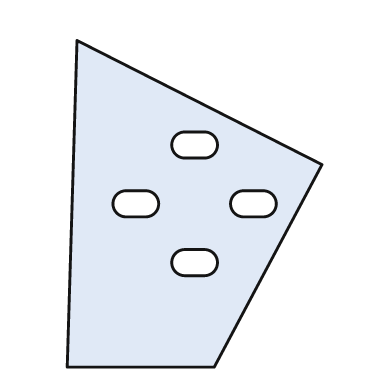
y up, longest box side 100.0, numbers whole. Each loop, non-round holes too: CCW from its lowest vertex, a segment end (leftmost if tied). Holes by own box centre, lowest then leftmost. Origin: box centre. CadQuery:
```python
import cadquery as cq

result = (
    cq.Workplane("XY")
    .moveTo(-39.0, -50.0)
    .lineTo(6.0, -50.0)
    .lineTo(39.0, 12.0)
    .lineTo(-36.0, 50.0)
    .close()
    .moveTo(-3.0, -22.0)
    .lineTo(3.0, -22.0)
    .threePointArc((7.0, -18.0), (3.0, -14.0))
    .lineTo(-3.0, -14.0)
    .threePointArc((-7.0, -18.0), (-3.0, -22.0))
    .close()
    .moveTo(-21.0, -4.0)
    .lineTo(-15.0, -4.0)
    .threePointArc((-11.0, 0.0), (-15.0, 4.0))
    .lineTo(-21.0, 4.0)
    .threePointArc((-25.0, 0.0), (-21.0, -4.0))
    .close()
    .moveTo(15.0, -4.0)
    .lineTo(21.0, -4.0)
    .threePointArc((25.0, 0.0), (21.0, 4.0))
    .lineTo(15.0, 4.0)
    .threePointArc((11.0, 0.0), (15.0, -4.0))
    .close()
    .moveTo(-3.0, 14.0)
    .lineTo(3.0, 14.0)
    .threePointArc((7.0, 18.0), (3.0, 22.0))
    .lineTo(-3.0, 22.0)
    .threePointArc((-7.0, 18.0), (-3.0, 14.0))
    .close()
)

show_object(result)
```